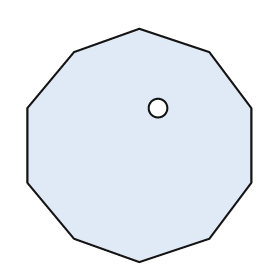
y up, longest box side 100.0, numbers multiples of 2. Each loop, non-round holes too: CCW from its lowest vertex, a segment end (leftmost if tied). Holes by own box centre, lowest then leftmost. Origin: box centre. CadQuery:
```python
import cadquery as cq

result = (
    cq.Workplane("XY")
    .moveTo(0.0, -50.0)
    .lineTo(30.0, -40.0)
    .lineTo(48.0, -16.0)
    .lineTo(48.0, 16.0)
    .lineTo(30.0, 40.0)
    .lineTo(0.0, 50.0)
    .lineTo(-28.0, 40.0)
    .lineTo(-48.0, 16.0)
    .lineTo(-48.0, -16.0)
    .lineTo(-28.0, -40.0)
    .close()
    .moveTo(8.0, 16.0)
    .circle(4.0)
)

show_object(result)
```